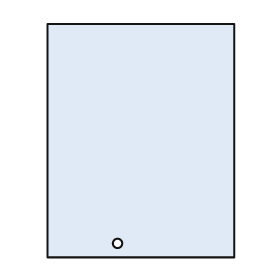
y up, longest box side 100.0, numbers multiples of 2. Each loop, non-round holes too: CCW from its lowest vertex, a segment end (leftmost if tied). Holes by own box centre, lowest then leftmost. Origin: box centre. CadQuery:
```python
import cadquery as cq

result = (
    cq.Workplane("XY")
    .moveTo(-40.0, -50.0)
    .lineTo(40.0, -50.0)
    .lineTo(40.0, 50.0)
    .lineTo(-40.0, 50.0)
    .close()
    .moveTo(-10.0, -44.0)
    .circle(2.0)
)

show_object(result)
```